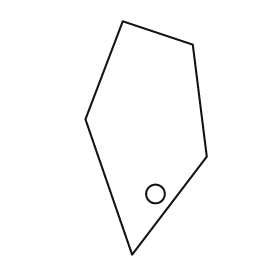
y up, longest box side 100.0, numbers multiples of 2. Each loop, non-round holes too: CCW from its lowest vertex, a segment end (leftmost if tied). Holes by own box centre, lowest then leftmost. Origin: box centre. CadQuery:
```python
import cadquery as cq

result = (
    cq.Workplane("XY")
    .moveTo(-6.0, -50.0)
    .lineTo(26.0, -8.0)
    .lineTo(20.0, 40.0)
    .lineTo(-10.0, 50.0)
    .lineTo(-26.0, 8.0)
    .close()
    .moveTo(4.0, -24.0)
    .circle(4.0)
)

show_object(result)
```